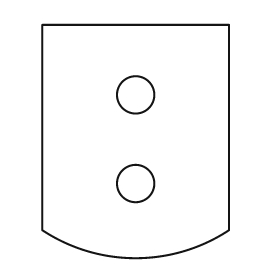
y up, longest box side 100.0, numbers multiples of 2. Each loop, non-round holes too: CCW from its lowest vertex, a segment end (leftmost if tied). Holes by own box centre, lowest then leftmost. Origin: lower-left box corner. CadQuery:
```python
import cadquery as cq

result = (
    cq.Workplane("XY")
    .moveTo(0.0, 12.0)
    .threePointArc((40.0, 0.0), (80.0, 12.0))
    .lineTo(80.0, 100.0)
    .lineTo(0.0, 100.0)
    .close()
    .moveTo(40.0, 32.0)
    .circle(8.0)
    .moveTo(40.0, 70.0)
    .circle(8.0)
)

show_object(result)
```